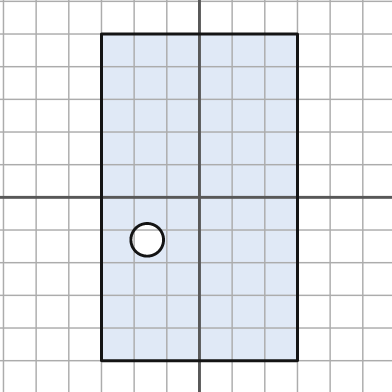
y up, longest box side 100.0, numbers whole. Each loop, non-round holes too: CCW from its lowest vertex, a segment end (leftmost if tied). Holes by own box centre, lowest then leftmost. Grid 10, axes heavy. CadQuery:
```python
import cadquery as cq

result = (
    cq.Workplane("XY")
    .moveTo(-30.0, -50.0)
    .lineTo(30.0, -50.0)
    .lineTo(30.0, 50.0)
    .lineTo(-30.0, 50.0)
    .close()
    .moveTo(-16.0, -13.0)
    .circle(5.0)
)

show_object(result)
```